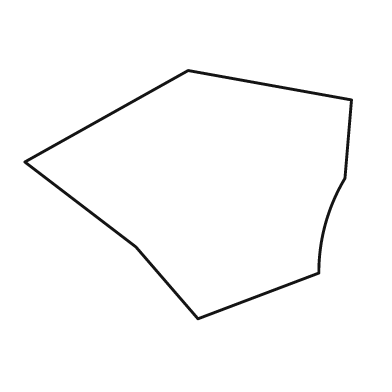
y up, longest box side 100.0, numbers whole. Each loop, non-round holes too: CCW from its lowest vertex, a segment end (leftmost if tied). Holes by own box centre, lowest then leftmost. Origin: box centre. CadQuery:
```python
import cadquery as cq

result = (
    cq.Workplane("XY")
    .moveTo(3.0, -38.0)
    .lineTo(40.0, -24.0)
    .threePointArc((42.0, -9.0), (48.0, 5.0))
    .lineTo(50.0, 29.0)
    .lineTo(0.0, 38.0)
    .lineTo(-50.0, 10.0)
    .lineTo(-16.0, -16.0)
    .close()
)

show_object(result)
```